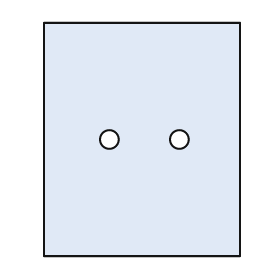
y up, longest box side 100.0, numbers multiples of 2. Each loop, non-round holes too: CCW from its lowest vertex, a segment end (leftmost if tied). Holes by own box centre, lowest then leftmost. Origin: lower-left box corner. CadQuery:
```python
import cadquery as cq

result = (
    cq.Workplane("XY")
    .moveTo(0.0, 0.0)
    .lineTo(84.0, 0.0)
    .lineTo(84.0, 100.0)
    .lineTo(0.0, 100.0)
    .close()
    .moveTo(28.0, 50.0)
    .circle(4.0)
    .moveTo(58.0, 50.0)
    .circle(4.0)
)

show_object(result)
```